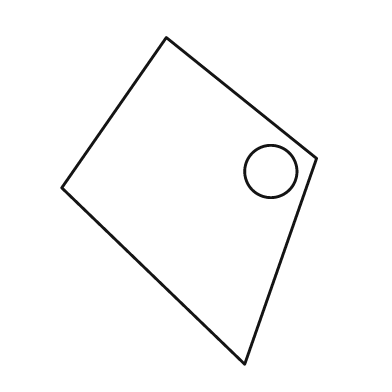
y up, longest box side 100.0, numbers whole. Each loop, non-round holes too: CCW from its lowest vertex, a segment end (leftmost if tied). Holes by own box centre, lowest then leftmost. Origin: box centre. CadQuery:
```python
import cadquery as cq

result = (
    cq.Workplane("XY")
    .moveTo(17.0, -50.0)
    .lineTo(39.0, 13.0)
    .lineTo(-7.0, 50.0)
    .lineTo(-39.0, 4.0)
    .close()
    .moveTo(25.0, 9.0)
    .circle(8.0)
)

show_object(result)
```